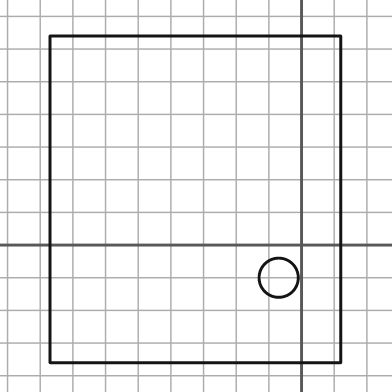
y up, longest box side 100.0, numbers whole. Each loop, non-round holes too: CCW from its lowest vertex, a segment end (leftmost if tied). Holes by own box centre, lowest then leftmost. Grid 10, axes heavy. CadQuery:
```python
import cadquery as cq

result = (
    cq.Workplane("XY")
    .moveTo(-77.0, -36.0)
    .lineTo(12.0, -36.0)
    .lineTo(12.0, 64.0)
    .lineTo(-77.0, 64.0)
    .close()
    .moveTo(-7.0, -10.0)
    .circle(6.0)
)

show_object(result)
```